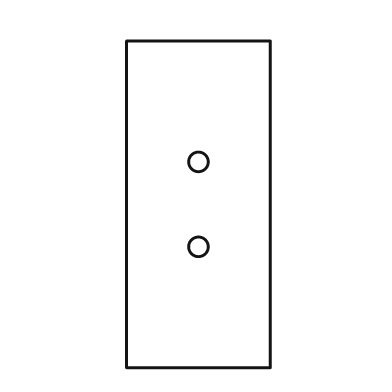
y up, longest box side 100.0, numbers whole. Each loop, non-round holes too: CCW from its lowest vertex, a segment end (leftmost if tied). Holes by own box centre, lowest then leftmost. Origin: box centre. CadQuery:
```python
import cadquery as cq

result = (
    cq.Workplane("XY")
    .moveTo(-22.0, -50.0)
    .lineTo(22.0, -50.0)
    .lineTo(22.0, 50.0)
    .lineTo(-22.0, 50.0)
    .close()
    .moveTo(0.0, -13.0)
    .circle(3.0)
    .moveTo(0.0, 13.0)
    .circle(3.0)
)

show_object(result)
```